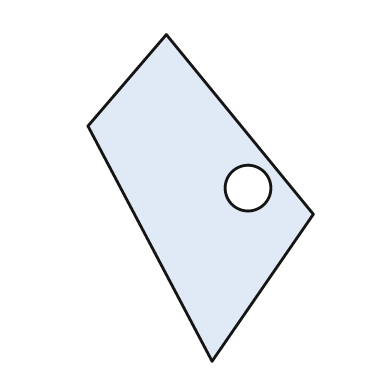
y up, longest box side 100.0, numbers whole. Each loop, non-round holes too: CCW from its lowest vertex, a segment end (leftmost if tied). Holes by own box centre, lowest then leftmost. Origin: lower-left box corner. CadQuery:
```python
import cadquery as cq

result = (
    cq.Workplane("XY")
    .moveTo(38.0, 0.0)
    .lineTo(69.0, 45.0)
    .lineTo(24.0, 100.0)
    .lineTo(0.0, 72.0)
    .close()
    .moveTo(49.0, 53.0)
    .circle(7.0)
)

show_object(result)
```